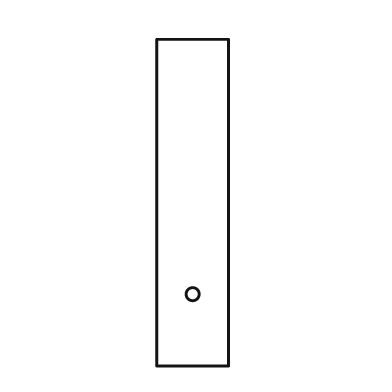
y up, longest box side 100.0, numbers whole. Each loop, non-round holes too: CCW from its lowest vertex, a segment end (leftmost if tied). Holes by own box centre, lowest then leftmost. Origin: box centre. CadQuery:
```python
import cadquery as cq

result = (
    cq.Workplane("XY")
    .moveTo(-11.0, -50.0)
    .lineTo(11.0, -50.0)
    .lineTo(11.0, 50.0)
    .lineTo(-11.0, 50.0)
    .close()
    .moveTo(0.0, -28.0)
    .circle(2.0)
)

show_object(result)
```